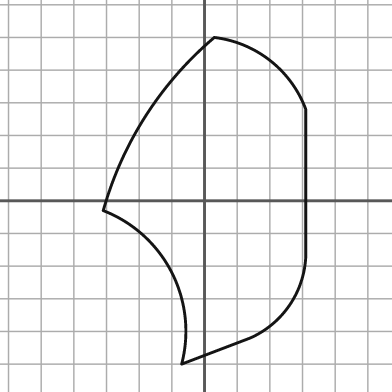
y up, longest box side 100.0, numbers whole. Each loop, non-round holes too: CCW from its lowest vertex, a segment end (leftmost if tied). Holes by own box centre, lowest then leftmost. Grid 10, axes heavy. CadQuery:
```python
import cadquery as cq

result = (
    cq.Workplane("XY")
    .moveTo(-7.0, -50.0)
    .lineTo(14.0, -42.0)
    .threePointArc((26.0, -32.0), (31.0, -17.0))
    .lineTo(31.0, 28.0)
    .threePointArc((20.0, 43.0), (3.0, 50.0))
    .threePointArc((-18.0, 26.0), (-31.0, -3.0))
    .threePointArc((-10.0, -22.0), (-7.0, -50.0))
    .close()
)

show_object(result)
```